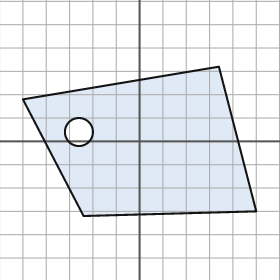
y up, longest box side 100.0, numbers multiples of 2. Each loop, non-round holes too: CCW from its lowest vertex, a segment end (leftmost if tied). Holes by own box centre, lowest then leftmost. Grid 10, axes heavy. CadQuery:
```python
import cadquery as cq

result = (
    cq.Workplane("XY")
    .moveTo(-24.0, -32.0)
    .lineTo(50.0, -30.0)
    .lineTo(34.0, 32.0)
    .lineTo(-50.0, 18.0)
    .close()
    .moveTo(-26.0, 4.0)
    .circle(6.0)
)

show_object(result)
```